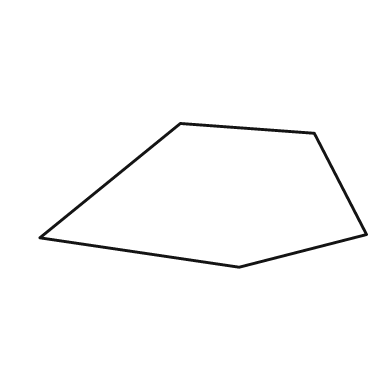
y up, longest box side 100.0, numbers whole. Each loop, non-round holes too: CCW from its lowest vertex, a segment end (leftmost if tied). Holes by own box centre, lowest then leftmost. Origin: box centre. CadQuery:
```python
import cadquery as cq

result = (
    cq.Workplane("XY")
    .moveTo(11.0, -22.0)
    .lineTo(50.0, -12.0)
    .lineTo(34.0, 19.0)
    .lineTo(-7.0, 22.0)
    .lineTo(-50.0, -13.0)
    .close()
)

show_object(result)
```